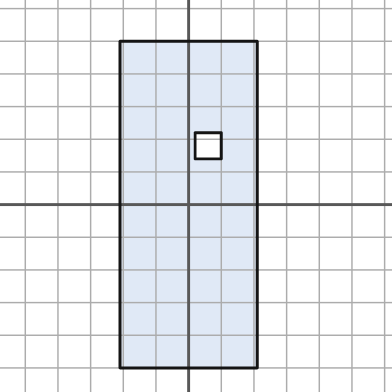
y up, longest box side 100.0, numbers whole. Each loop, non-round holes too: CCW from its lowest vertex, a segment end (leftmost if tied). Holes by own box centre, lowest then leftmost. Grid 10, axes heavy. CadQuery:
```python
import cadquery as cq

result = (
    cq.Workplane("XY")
    .moveTo(-21.0, -50.0)
    .lineTo(21.0, -50.0)
    .lineTo(21.0, 50.0)
    .lineTo(-21.0, 50.0)
    .close()
    .moveTo(2.0, 14.0)
    .lineTo(10.0, 14.0)
    .lineTo(10.0, 22.0)
    .lineTo(2.0, 22.0)
    .close()
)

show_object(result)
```